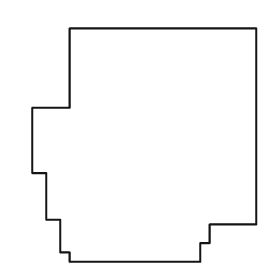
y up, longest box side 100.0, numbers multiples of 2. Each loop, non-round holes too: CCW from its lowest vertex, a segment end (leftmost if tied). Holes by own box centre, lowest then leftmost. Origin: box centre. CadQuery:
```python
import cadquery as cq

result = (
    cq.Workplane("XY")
    .moveTo(-32.0, -50.0)
    .lineTo(24.0, -50.0)
    .lineTo(24.0, -42.0)
    .lineTo(28.0, -42.0)
    .lineTo(28.0, -34.0)
    .lineTo(48.0, -34.0)
    .lineTo(48.0, 50.0)
    .lineTo(-32.0, 50.0)
    .lineTo(-32.0, 16.0)
    .lineTo(-48.0, 16.0)
    .lineTo(-48.0, -12.0)
    .lineTo(-42.0, -12.0)
    .lineTo(-42.0, -32.0)
    .lineTo(-36.0, -32.0)
    .lineTo(-36.0, -46.0)
    .lineTo(-32.0, -46.0)
    .close()
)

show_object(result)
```